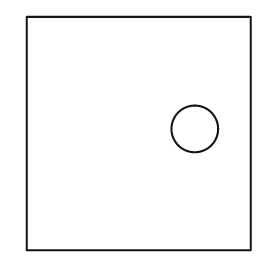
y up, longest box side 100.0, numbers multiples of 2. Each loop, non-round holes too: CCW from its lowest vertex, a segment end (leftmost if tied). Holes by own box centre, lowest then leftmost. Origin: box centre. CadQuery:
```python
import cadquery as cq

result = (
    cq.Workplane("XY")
    .moveTo(-48.0, -50.0)
    .lineTo(48.0, -50.0)
    .lineTo(48.0, 50.0)
    .lineTo(-48.0, 50.0)
    .close()
    .moveTo(24.0, 2.0)
    .circle(10.0)
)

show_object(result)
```